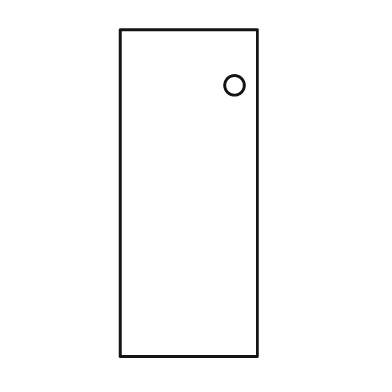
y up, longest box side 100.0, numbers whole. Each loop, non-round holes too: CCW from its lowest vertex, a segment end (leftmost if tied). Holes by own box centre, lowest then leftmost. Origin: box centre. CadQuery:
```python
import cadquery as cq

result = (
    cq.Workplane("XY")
    .moveTo(-21.0, -50.0)
    .lineTo(21.0, -50.0)
    .lineTo(21.0, 50.0)
    .lineTo(-21.0, 50.0)
    .close()
    .moveTo(14.0, 33.0)
    .circle(3.0)
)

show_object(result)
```